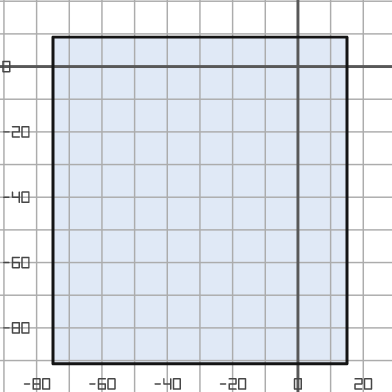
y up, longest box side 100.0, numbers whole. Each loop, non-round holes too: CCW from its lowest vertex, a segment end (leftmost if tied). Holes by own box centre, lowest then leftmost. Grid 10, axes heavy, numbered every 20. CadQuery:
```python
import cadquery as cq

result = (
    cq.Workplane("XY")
    .moveTo(-75.0, -91.0)
    .lineTo(15.0, -91.0)
    .lineTo(15.0, 9.0)
    .lineTo(-75.0, 9.0)
    .close()
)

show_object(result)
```